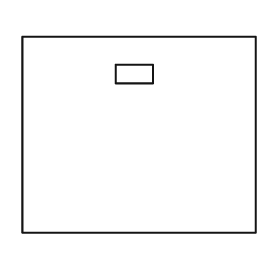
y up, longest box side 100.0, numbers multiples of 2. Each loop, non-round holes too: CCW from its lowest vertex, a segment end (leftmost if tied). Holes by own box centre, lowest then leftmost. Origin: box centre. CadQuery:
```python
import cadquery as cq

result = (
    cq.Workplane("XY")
    .moveTo(-50.0, -42.0)
    .lineTo(50.0, -42.0)
    .lineTo(50.0, 42.0)
    .lineTo(-50.0, 42.0)
    .close()
    .moveTo(-10.0, 22.0)
    .lineTo(6.0, 22.0)
    .lineTo(6.0, 30.0)
    .lineTo(-10.0, 30.0)
    .close()
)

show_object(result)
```